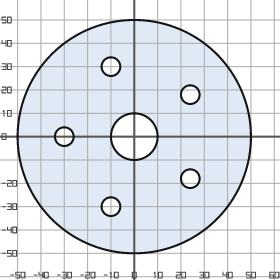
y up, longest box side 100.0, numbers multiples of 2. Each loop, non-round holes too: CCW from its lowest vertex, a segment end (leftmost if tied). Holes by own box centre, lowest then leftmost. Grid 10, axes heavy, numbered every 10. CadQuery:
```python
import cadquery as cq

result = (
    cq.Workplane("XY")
    .moveTo(0.0, 0.0)
    .circle(50.0)
    .moveTo(-10.0, -30.0)
    .circle(4.0)
    .moveTo(24.0, -18.0)
    .circle(4.0)
    .moveTo(-30.0, 0.0)
    .circle(4.0)
    .moveTo(0.0, 0.0)
    .circle(10.0)
    .moveTo(24.0, 18.0)
    .circle(4.0)
    .moveTo(-10.0, 30.0)
    .circle(4.0)
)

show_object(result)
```